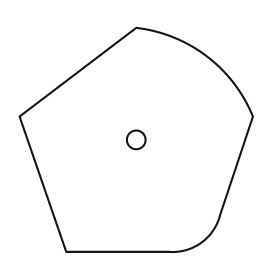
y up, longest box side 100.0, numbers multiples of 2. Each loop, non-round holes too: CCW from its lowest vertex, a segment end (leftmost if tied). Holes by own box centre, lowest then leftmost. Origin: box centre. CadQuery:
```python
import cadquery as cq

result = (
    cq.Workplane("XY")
    .moveTo(-30.0, -48.0)
    .lineTo(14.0, -48.0)
    .threePointArc((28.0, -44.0), (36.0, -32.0))
    .lineTo(50.0, 10.0)
    .threePointArc((30.0, 36.0), (0.0, 48.0))
    .lineTo(-50.0, 10.0)
    .close()
    .moveTo(0.0, 0.0)
    .circle(4.0)
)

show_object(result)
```